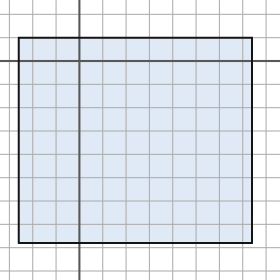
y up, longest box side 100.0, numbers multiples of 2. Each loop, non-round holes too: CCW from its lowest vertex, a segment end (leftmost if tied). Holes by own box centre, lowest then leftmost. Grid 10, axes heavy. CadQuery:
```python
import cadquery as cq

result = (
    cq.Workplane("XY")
    .moveTo(-26.0, -78.0)
    .lineTo(74.0, -78.0)
    .lineTo(74.0, 10.0)
    .lineTo(-26.0, 10.0)
    .close()
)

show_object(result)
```